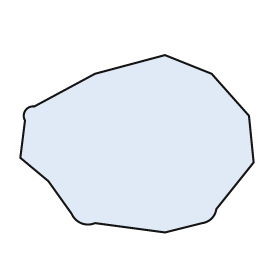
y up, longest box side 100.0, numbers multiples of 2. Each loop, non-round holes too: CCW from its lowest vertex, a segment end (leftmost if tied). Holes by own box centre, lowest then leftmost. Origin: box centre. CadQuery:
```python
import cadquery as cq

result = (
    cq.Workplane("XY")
    .moveTo(12.0, -38.0)
    .lineTo(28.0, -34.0)
    .threePointArc((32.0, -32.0), (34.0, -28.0))
    .lineTo(50.0, -8.0)
    .lineTo(48.0, 12.0)
    .lineTo(32.0, 30.0)
    .lineTo(12.0, 38.0)
    .lineTo(-18.0, 30.0)
    .lineTo(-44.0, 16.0)
    .threePointArc((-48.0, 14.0), (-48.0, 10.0))
    .lineTo(-50.0, -6.0)
    .lineTo(-38.0, -16.0)
    .lineTo(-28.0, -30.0)
    .threePointArc((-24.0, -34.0), (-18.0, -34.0))
    .close()
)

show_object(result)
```